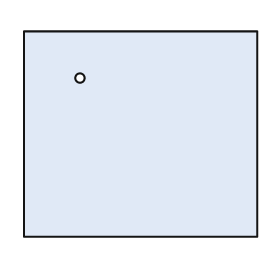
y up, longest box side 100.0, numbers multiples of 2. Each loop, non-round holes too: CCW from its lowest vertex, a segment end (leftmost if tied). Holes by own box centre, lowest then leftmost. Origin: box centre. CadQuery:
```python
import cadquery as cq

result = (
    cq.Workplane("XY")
    .moveTo(-50.0, -44.0)
    .lineTo(50.0, -44.0)
    .lineTo(50.0, 44.0)
    .lineTo(-50.0, 44.0)
    .close()
    .moveTo(-26.0, 24.0)
    .circle(2.0)
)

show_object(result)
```